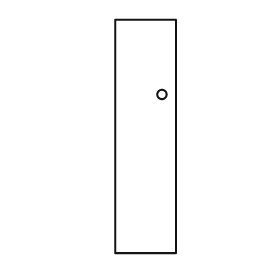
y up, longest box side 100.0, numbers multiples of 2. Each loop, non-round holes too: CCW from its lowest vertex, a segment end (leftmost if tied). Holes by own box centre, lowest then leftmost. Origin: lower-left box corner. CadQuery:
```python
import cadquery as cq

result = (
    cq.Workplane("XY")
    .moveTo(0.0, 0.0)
    .lineTo(26.0, 0.0)
    .lineTo(26.0, 100.0)
    .lineTo(0.0, 100.0)
    .close()
    .moveTo(20.0, 68.0)
    .circle(2.0)
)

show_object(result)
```